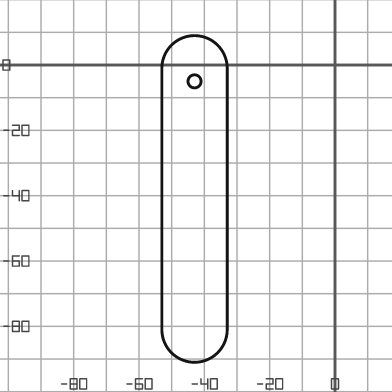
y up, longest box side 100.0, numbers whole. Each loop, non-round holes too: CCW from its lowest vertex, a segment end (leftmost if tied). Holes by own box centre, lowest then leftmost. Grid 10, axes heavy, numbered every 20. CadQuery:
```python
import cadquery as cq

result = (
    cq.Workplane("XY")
    .moveTo(-53.0, -81.0)
    .threePointArc((-43.0, -91.0), (-33.0, -81.0))
    .lineTo(-33.0, -1.0)
    .threePointArc((-43.0, 9.0), (-53.0, -1.0))
    .close()
    .moveTo(-43.0, -5.0)
    .circle(2.0)
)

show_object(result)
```